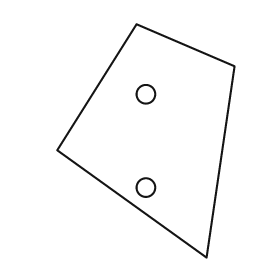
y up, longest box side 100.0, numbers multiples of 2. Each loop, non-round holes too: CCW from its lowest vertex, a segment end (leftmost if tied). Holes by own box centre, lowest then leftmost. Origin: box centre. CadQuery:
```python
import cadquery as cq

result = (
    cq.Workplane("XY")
    .moveTo(26.0, -50.0)
    .lineTo(38.0, 32.0)
    .lineTo(-4.0, 50.0)
    .lineTo(-38.0, -4.0)
    .close()
    .moveTo(0.0, -20.0)
    .circle(4.0)
    .moveTo(0.0, 20.0)
    .circle(4.0)
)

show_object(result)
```